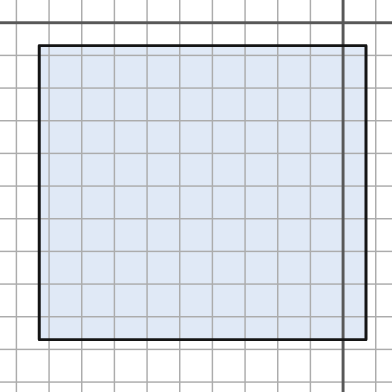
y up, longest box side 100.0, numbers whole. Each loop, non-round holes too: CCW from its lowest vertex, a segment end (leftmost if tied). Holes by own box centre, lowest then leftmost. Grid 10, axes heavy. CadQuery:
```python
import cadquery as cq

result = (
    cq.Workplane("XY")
    .moveTo(-93.0, -97.0)
    .lineTo(7.0, -97.0)
    .lineTo(7.0, -7.0)
    .lineTo(-93.0, -7.0)
    .close()
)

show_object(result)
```